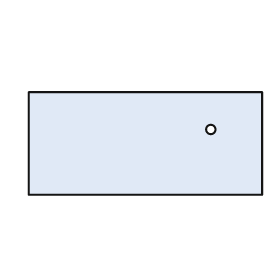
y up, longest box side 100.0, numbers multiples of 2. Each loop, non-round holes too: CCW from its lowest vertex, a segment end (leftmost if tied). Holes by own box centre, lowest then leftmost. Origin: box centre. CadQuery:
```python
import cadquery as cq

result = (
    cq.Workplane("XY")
    .moveTo(-50.0, -22.0)
    .lineTo(50.0, -22.0)
    .lineTo(50.0, 22.0)
    .lineTo(-50.0, 22.0)
    .close()
    .moveTo(28.0, 6.0)
    .circle(2.0)
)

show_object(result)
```